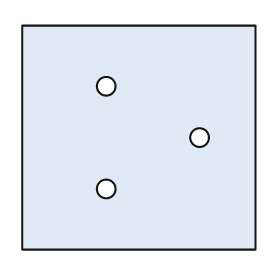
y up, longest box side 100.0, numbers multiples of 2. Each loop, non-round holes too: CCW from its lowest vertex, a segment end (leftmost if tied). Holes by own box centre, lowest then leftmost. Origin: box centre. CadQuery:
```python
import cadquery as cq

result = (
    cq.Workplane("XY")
    .moveTo(-50.0, -48.0)
    .lineTo(50.0, -48.0)
    .lineTo(50.0, 48.0)
    .lineTo(-50.0, 48.0)
    .close()
    .moveTo(-14.0, -22.0)
    .circle(4.0)
    .moveTo(26.0, 0.0)
    .circle(4.0)
    .moveTo(-14.0, 22.0)
    .circle(4.0)
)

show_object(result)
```